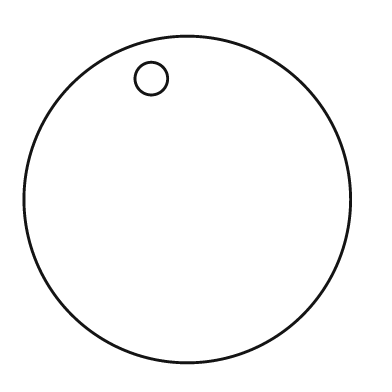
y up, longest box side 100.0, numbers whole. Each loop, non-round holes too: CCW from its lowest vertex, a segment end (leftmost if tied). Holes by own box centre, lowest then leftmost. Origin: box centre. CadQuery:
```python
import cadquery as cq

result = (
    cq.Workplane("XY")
    .moveTo(0.0, 0.0)
    .circle(50.0)
    .moveTo(-11.0, 37.0)
    .circle(5.0)
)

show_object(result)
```